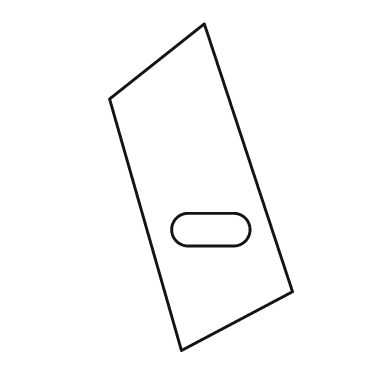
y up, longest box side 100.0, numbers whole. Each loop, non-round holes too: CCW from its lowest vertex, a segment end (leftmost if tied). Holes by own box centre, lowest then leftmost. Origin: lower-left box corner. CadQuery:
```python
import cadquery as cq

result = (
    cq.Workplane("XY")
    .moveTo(22.0, 0.0)
    .lineTo(56.0, 18.0)
    .lineTo(29.0, 100.0)
    .lineTo(0.0, 77.0)
    .close()
    .moveTo(24.0, 32.0)
    .lineTo(38.0, 32.0)
    .threePointArc((43.0, 37.0), (38.0, 42.0))
    .lineTo(24.0, 42.0)
    .threePointArc((19.0, 37.0), (24.0, 32.0))
    .close()
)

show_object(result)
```